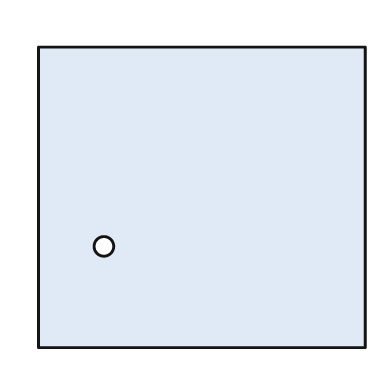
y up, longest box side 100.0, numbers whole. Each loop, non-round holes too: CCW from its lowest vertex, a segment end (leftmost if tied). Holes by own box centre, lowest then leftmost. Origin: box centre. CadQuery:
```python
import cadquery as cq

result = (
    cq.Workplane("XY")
    .moveTo(-50.0, -46.0)
    .lineTo(50.0, -46.0)
    .lineTo(50.0, 46.0)
    .lineTo(-50.0, 46.0)
    .close()
    .moveTo(-30.0, -15.0)
    .circle(3.0)
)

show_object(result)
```